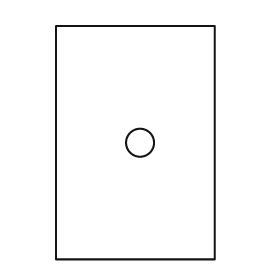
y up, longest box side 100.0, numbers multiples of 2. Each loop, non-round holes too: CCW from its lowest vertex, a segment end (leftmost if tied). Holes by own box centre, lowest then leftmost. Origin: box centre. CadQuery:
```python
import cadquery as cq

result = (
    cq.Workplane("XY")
    .moveTo(-34.0, -50.0)
    .lineTo(34.0, -50.0)
    .lineTo(34.0, 50.0)
    .lineTo(-34.0, 50.0)
    .close()
    .moveTo(2.0, 0.0)
    .circle(6.0)
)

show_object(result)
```